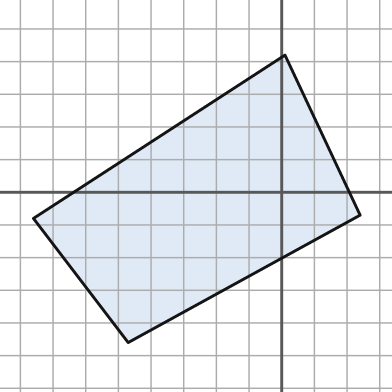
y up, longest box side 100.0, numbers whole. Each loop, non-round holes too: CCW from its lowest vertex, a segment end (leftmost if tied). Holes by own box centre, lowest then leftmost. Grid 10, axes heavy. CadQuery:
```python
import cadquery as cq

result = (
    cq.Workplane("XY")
    .moveTo(-47.0, -46.0)
    .lineTo(24.0, -7.0)
    .lineTo(1.0, 42.0)
    .lineTo(-76.0, -8.0)
    .close()
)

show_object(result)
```